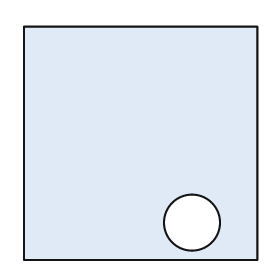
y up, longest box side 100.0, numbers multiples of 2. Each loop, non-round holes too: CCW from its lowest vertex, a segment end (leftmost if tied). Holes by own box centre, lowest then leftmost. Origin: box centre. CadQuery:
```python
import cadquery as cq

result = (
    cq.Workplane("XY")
    .moveTo(-50.0, -50.0)
    .lineTo(50.0, -50.0)
    .lineTo(50.0, 50.0)
    .lineTo(-50.0, 50.0)
    .close()
    .moveTo(22.0, -34.0)
    .circle(12.0)
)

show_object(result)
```